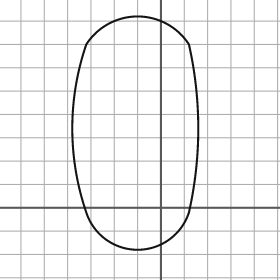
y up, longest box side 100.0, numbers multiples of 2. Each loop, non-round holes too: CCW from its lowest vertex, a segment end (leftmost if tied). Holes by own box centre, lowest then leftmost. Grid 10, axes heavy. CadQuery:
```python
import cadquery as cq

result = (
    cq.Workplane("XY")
    .moveTo(-32.0, -2.0)
    .threePointArc((-10.0, -18.0), (12.0, -2.0))
    .threePointArc((16.0, 34.0), (12.0, 70.0))
    .threePointArc((-10.0, 82.0), (-32.0, 70.0))
    .threePointArc((-38.0, 34.0), (-32.0, -2.0))
    .close()
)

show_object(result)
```